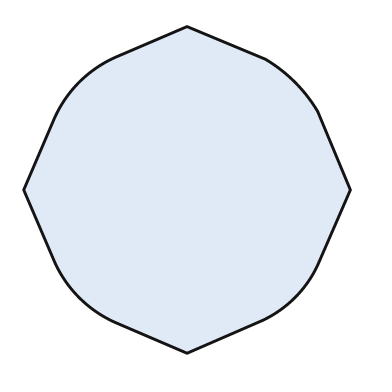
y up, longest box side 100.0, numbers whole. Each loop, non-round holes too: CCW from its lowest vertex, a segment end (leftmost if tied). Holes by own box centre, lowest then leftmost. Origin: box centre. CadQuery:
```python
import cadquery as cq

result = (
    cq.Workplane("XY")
    .moveTo(0.0, -50.0)
    .lineTo(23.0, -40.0)
    .threePointArc((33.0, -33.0), (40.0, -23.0))
    .lineTo(50.0, 0.0)
    .lineTo(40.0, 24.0)
    .threePointArc((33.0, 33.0), (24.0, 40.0))
    .lineTo(0.0, 50.0)
    .lineTo(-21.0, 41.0)
    .threePointArc((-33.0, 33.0), (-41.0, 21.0))
    .lineTo(-50.0, 0.0)
    .lineTo(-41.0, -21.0)
    .threePointArc((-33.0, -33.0), (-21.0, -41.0))
    .close()
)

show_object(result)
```